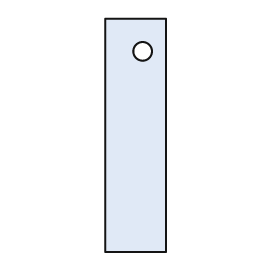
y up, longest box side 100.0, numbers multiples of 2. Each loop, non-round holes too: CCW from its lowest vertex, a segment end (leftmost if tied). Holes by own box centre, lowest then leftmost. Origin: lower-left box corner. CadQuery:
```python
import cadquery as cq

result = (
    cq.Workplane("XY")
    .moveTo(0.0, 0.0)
    .lineTo(26.0, 0.0)
    .lineTo(26.0, 100.0)
    .lineTo(0.0, 100.0)
    .close()
    .moveTo(16.0, 86.0)
    .circle(4.0)
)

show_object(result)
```